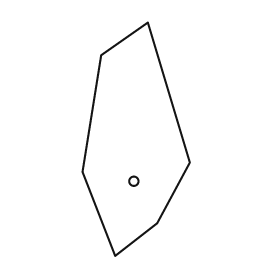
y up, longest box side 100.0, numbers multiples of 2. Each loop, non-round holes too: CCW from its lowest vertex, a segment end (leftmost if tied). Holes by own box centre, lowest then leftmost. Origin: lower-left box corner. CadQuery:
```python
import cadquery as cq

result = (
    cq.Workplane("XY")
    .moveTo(14.0, 0.0)
    .lineTo(32.0, 14.0)
    .lineTo(46.0, 40.0)
    .lineTo(28.0, 100.0)
    .lineTo(8.0, 86.0)
    .lineTo(0.0, 36.0)
    .close()
    .moveTo(22.0, 32.0)
    .circle(2.0)
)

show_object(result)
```